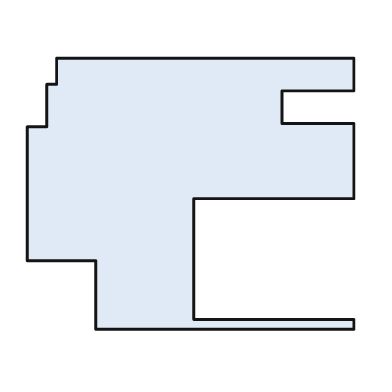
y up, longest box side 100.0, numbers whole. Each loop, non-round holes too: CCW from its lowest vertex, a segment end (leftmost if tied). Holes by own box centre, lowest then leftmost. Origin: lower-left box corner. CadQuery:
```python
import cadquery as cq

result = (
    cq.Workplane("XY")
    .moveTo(21.0, 0.0)
    .lineTo(100.0, 0.0)
    .lineTo(100.0, 3.0)
    .lineTo(51.0, 3.0)
    .lineTo(51.0, 40.0)
    .lineTo(100.0, 40.0)
    .lineTo(100.0, 63.0)
    .lineTo(78.0, 63.0)
    .lineTo(78.0, 73.0)
    .lineTo(100.0, 73.0)
    .lineTo(100.0, 83.0)
    .lineTo(9.0, 83.0)
    .lineTo(9.0, 75.0)
    .lineTo(6.0, 75.0)
    .lineTo(6.0, 62.0)
    .lineTo(0.0, 62.0)
    .lineTo(0.0, 21.0)
    .lineTo(21.0, 21.0)
    .close()
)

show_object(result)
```